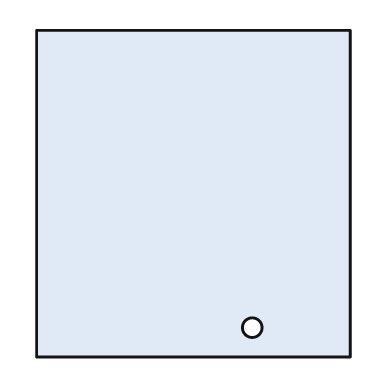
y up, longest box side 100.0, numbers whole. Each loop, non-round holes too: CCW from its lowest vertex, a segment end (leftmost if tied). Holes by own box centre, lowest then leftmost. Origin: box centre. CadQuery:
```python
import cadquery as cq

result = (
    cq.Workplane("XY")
    .moveTo(-48.0, -50.0)
    .lineTo(48.0, -50.0)
    .lineTo(48.0, 50.0)
    .lineTo(-48.0, 50.0)
    .close()
    .moveTo(18.0, -41.0)
    .circle(3.0)
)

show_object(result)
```